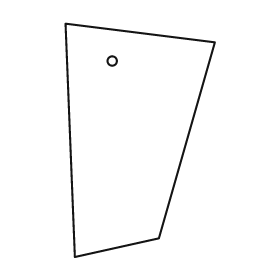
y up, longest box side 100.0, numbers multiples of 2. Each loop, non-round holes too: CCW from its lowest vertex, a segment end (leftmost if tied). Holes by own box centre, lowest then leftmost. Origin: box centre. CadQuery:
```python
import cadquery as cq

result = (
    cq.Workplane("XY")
    .moveTo(-28.0, -50.0)
    .lineTo(8.0, -42.0)
    .lineTo(32.0, 42.0)
    .lineTo(-32.0, 50.0)
    .close()
    .moveTo(-12.0, 34.0)
    .circle(2.0)
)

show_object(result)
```